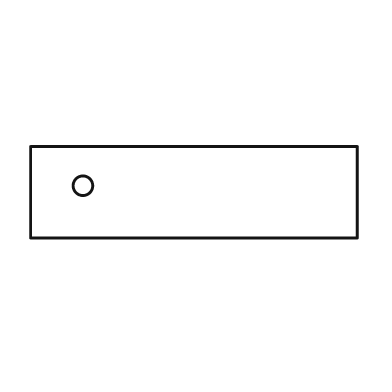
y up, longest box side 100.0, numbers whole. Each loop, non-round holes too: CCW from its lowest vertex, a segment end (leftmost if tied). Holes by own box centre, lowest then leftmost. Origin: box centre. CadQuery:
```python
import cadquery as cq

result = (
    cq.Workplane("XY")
    .moveTo(-50.0, -14.0)
    .lineTo(50.0, -14.0)
    .lineTo(50.0, 14.0)
    .lineTo(-50.0, 14.0)
    .close()
    .moveTo(-34.0, 2.0)
    .circle(3.0)
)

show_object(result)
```